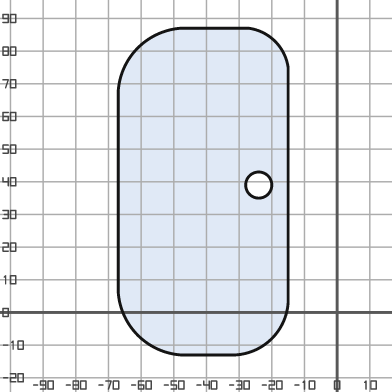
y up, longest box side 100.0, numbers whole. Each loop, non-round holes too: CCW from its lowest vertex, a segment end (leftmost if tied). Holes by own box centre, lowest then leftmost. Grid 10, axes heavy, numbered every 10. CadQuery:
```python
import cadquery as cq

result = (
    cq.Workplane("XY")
    .moveTo(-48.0, -13.0)
    .lineTo(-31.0, -13.0)
    .threePointArc((-20.0, -8.0), (-15.0, 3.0))
    .lineTo(-15.0, 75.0)
    .threePointArc((-19.0, 83.0), (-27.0, 87.0))
    .lineTo(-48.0, 87.0)
    .threePointArc((-61.0, 81.0), (-67.0, 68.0))
    .lineTo(-67.0, 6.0)
    .threePointArc((-61.0, -7.0), (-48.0, -13.0))
    .close()
    .moveTo(-24.0, 39.0)
    .circle(4.0)
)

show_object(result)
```